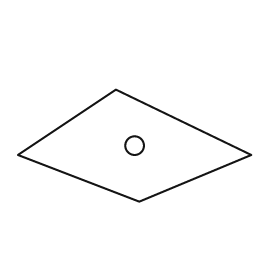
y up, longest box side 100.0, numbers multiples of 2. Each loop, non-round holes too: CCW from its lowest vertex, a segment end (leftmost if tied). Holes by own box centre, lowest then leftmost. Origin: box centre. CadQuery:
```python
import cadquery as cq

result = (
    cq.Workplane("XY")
    .moveTo(2.0, -24.0)
    .lineTo(50.0, -4.0)
    .lineTo(-8.0, 24.0)
    .lineTo(-50.0, -4.0)
    .close()
    .moveTo(0.0, 0.0)
    .circle(4.0)
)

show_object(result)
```